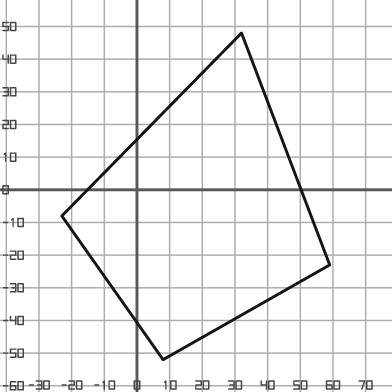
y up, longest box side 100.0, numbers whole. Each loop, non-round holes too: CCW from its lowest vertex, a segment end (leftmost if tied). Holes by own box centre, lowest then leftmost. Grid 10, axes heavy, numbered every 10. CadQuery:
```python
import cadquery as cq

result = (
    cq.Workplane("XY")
    .moveTo(8.0, -52.0)
    .lineTo(59.0, -23.0)
    .lineTo(32.0, 48.0)
    .lineTo(-23.0, -8.0)
    .close()
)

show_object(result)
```